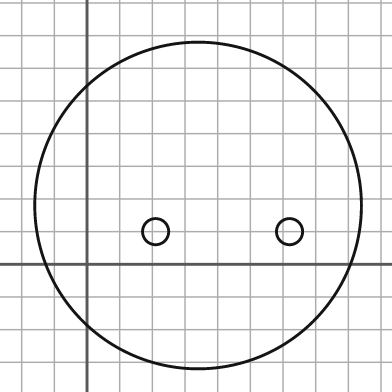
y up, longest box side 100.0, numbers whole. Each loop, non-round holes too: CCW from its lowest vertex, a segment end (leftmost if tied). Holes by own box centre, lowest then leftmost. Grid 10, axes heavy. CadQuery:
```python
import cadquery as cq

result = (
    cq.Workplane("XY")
    .moveTo(34.0, 18.0)
    .circle(50.0)
    .moveTo(21.0, 10.0)
    .circle(4.0)
    .moveTo(62.0, 10.0)
    .circle(4.0)
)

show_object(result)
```